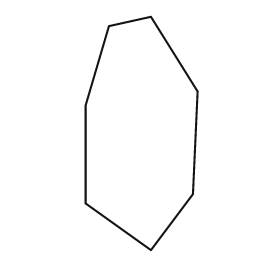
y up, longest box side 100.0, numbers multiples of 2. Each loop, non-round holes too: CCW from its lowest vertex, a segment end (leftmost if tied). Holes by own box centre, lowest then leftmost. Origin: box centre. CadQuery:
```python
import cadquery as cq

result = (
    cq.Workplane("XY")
    .moveTo(4.0, -50.0)
    .lineTo(22.0, -26.0)
    .lineTo(24.0, 18.0)
    .lineTo(4.0, 50.0)
    .lineTo(-14.0, 46.0)
    .lineTo(-24.0, 12.0)
    .lineTo(-24.0, -30.0)
    .close()
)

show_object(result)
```